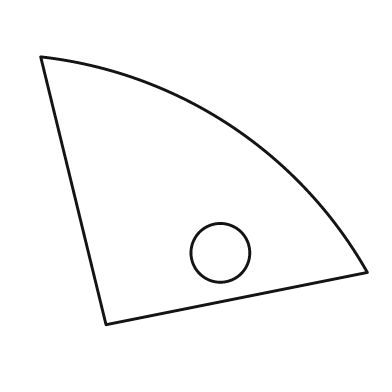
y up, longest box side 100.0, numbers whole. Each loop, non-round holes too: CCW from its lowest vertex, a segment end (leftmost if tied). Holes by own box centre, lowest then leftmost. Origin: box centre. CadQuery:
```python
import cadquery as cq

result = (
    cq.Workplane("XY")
    .moveTo(-30.0, -41.0)
    .lineTo(50.0, -25.0)
    .threePointArc((8.0, 20.0), (-50.0, 41.0))
    .close()
    .moveTo(5.0, -19.0)
    .circle(9.0)
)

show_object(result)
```